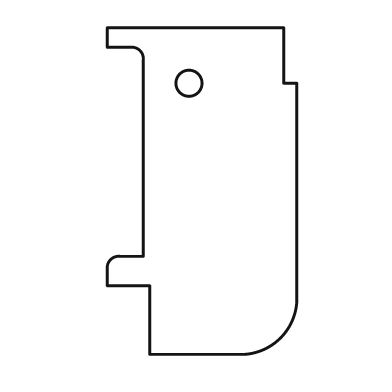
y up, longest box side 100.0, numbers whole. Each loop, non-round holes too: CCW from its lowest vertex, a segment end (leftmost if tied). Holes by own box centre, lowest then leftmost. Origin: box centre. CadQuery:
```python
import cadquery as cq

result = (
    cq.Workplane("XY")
    .moveTo(-16.0, -50.0)
    .lineTo(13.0, -50.0)
    .threePointArc((24.0, -45.0), (29.0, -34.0))
    .lineTo(29.0, 33.0)
    .lineTo(25.0, 33.0)
    .lineTo(25.0, 50.0)
    .lineTo(-29.0, 50.0)
    .lineTo(-29.0, 44.0)
    .lineTo(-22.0, 44.0)
    .threePointArc((-19.0, 43.0), (-18.0, 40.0))
    .lineTo(-18.0, -20.0)
    .lineTo(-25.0, -20.0)
    .threePointArc((-28.0, -21.0), (-29.0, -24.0))
    .lineTo(-29.0, -29.0)
    .lineTo(-16.0, -29.0)
    .close()
    .moveTo(-4.0, 33.0)
    .circle(4.0)
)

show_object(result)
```